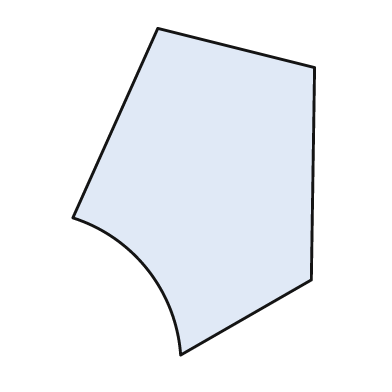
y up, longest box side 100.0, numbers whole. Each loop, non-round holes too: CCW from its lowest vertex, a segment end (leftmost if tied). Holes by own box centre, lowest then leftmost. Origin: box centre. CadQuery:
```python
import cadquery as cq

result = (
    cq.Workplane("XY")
    .moveTo(-4.0, -50.0)
    .lineTo(36.0, -27.0)
    .lineTo(37.0, 38.0)
    .lineTo(-11.0, 50.0)
    .lineTo(-37.0, -8.0)
    .threePointArc((-14.0, -24.0), (-4.0, -50.0))
    .close()
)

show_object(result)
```